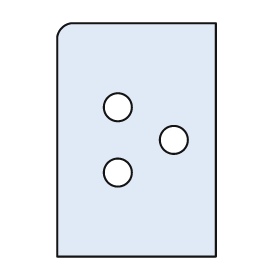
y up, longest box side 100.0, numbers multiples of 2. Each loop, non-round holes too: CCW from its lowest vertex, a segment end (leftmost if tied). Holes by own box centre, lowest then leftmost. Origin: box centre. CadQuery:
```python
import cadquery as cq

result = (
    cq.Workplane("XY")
    .moveTo(-34.0, -50.0)
    .lineTo(34.0, -50.0)
    .lineTo(34.0, 50.0)
    .lineTo(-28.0, 50.0)
    .threePointArc((-32.0, 48.0), (-34.0, 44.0))
    .close()
    .moveTo(-8.0, -14.0)
    .circle(6.0)
    .moveTo(16.0, 0.0)
    .circle(6.0)
    .moveTo(-8.0, 14.0)
    .circle(6.0)
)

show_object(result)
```